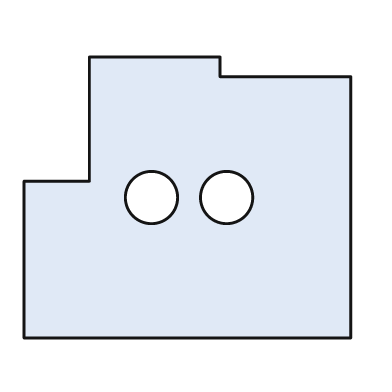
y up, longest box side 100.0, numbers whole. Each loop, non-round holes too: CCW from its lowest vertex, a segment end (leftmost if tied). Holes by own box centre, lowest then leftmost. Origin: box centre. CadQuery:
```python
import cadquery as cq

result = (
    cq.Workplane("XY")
    .moveTo(-50.0, -43.0)
    .lineTo(50.0, -43.0)
    .lineTo(50.0, 37.0)
    .lineTo(10.0, 37.0)
    .lineTo(10.0, 43.0)
    .lineTo(-30.0, 43.0)
    .lineTo(-30.0, 5.0)
    .lineTo(-50.0, 5.0)
    .close()
    .moveTo(-11.0, 0.0)
    .circle(8.0)
    .moveTo(12.0, 0.0)
    .circle(8.0)
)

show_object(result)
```